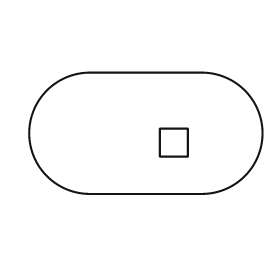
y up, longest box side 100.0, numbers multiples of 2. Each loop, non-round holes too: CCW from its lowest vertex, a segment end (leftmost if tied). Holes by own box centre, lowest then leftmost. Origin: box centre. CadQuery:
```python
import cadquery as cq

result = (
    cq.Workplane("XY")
    .moveTo(-24.0, -26.0)
    .lineTo(24.0, -26.0)
    .threePointArc((50.0, 0.0), (24.0, 26.0))
    .lineTo(-24.0, 26.0)
    .threePointArc((-50.0, 0.0), (-24.0, -26.0))
    .close()
    .moveTo(6.0, -10.0)
    .lineTo(18.0, -10.0)
    .lineTo(18.0, 2.0)
    .lineTo(6.0, 2.0)
    .close()
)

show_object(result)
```